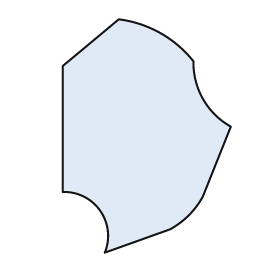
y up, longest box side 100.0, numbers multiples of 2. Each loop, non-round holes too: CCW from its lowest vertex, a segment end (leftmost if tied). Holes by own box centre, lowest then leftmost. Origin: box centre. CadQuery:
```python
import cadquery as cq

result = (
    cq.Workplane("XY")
    .moveTo(-18.0, -50.0)
    .lineTo(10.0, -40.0)
    .threePointArc((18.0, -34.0), (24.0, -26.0))
    .lineTo(36.0, 4.0)
    .threePointArc((24.0, 16.0), (20.0, 32.0))
    .threePointArc((6.0, 44.0), (-12.0, 50.0))
    .lineTo(-36.0, 30.0)
    .lineTo(-36.0, -24.0)
    .threePointArc((-20.0, -32.0), (-18.0, -50.0))
    .close()
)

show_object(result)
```